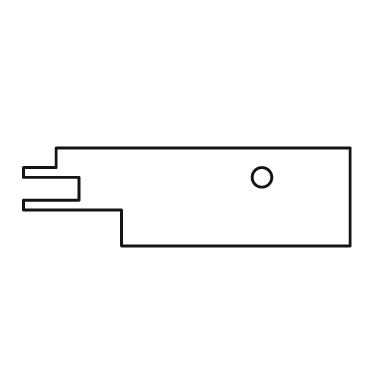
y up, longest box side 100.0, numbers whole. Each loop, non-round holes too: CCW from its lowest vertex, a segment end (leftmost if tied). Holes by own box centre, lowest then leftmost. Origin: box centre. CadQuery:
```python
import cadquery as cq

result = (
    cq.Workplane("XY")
    .moveTo(-20.0, -15.0)
    .lineTo(50.0, -15.0)
    .lineTo(50.0, 15.0)
    .lineTo(-40.0, 15.0)
    .lineTo(-40.0, 9.0)
    .lineTo(-50.0, 9.0)
    .lineTo(-50.0, 6.0)
    .lineTo(-33.0, 6.0)
    .lineTo(-33.0, -1.0)
    .lineTo(-50.0, -1.0)
    .lineTo(-50.0, -4.0)
    .lineTo(-20.0, -4.0)
    .close()
    .moveTo(23.0, 6.0)
    .circle(3.0)
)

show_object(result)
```